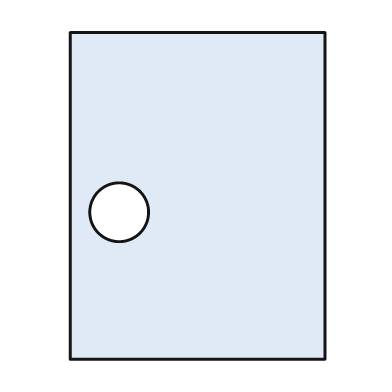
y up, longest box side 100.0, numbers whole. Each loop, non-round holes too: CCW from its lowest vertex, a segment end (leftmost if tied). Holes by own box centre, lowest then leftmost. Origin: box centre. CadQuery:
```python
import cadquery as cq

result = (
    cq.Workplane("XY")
    .moveTo(-39.0, -50.0)
    .lineTo(39.0, -50.0)
    .lineTo(39.0, 50.0)
    .lineTo(-39.0, 50.0)
    .close()
    .moveTo(-24.0, -5.0)
    .circle(9.0)
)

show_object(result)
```